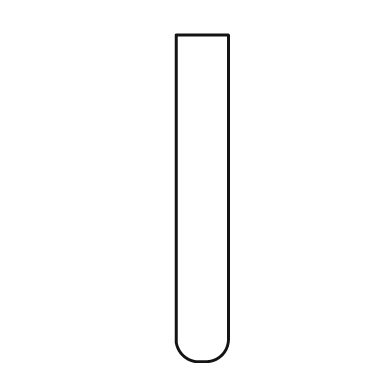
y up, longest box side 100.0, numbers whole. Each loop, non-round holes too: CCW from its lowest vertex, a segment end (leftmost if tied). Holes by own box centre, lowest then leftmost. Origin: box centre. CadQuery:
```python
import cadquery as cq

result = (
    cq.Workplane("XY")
    .moveTo(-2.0, -50.0)
    .lineTo(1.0, -50.0)
    .threePointArc((6.0, -48.0), (8.0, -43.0))
    .lineTo(8.0, 50.0)
    .lineTo(-8.0, 50.0)
    .lineTo(-8.0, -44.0)
    .threePointArc((-6.0, -48.0), (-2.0, -50.0))
    .close()
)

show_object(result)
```